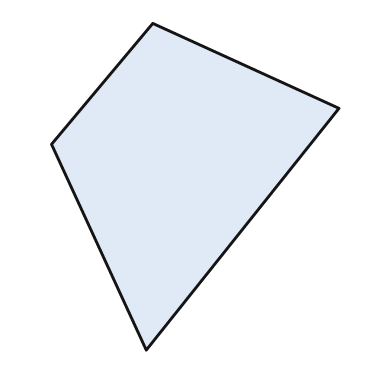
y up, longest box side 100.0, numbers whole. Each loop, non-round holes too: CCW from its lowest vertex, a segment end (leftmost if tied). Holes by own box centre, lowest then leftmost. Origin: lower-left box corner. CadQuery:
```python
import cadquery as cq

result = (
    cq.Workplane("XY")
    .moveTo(29.0, 0.0)
    .lineTo(88.0, 74.0)
    .lineTo(31.0, 100.0)
    .lineTo(0.0, 63.0)
    .close()
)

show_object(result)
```